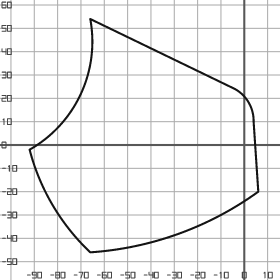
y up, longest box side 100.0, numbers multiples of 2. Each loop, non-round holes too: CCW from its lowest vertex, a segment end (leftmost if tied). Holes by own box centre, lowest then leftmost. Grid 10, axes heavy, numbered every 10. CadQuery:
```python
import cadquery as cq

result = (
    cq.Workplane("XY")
    .moveTo(-66.0, -46.0)
    .threePointArc((-28.0, -38.0), (6.0, -20.0))
    .lineTo(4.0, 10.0)
    .threePointArc((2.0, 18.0), (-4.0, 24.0))
    .lineTo(-66.0, 54.0)
    .threePointArc((-70.0, 22.0), (-92.0, -2.0))
    .threePointArc((-82.0, -26.0), (-66.0, -46.0))
    .close()
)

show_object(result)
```